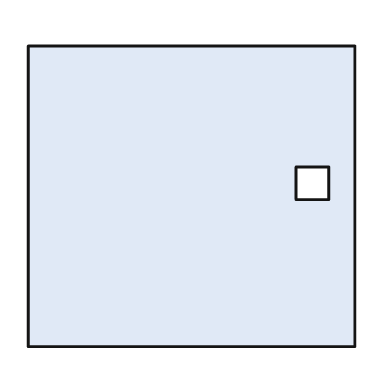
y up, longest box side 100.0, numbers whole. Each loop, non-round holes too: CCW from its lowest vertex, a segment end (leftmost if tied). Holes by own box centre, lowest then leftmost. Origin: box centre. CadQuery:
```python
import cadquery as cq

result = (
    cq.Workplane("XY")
    .moveTo(-50.0, -46.0)
    .lineTo(50.0, -46.0)
    .lineTo(50.0, 46.0)
    .lineTo(-50.0, 46.0)
    .close()
    .moveTo(32.0, -1.0)
    .lineTo(42.0, -1.0)
    .lineTo(42.0, 9.0)
    .lineTo(32.0, 9.0)
    .close()
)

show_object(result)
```